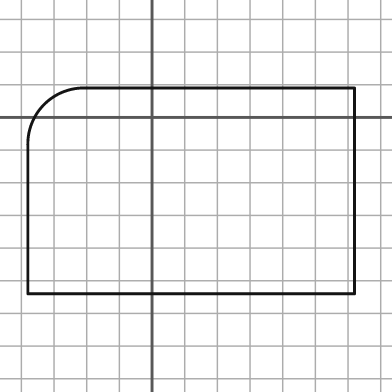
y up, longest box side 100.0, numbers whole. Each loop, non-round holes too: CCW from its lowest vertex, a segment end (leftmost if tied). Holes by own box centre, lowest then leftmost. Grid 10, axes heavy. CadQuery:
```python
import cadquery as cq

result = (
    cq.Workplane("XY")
    .moveTo(-38.0, -54.0)
    .lineTo(62.0, -54.0)
    .lineTo(62.0, 9.0)
    .lineTo(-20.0, 9.0)
    .threePointArc((-33.0, 4.0), (-38.0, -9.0))
    .close()
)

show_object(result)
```